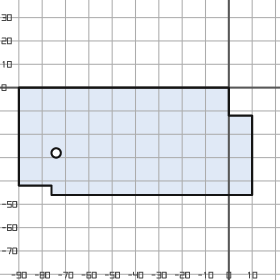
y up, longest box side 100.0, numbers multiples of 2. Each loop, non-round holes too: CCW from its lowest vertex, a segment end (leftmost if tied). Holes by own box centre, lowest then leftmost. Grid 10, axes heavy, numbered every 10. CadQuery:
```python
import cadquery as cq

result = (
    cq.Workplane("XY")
    .moveTo(-76.0, -46.0)
    .lineTo(10.0, -46.0)
    .lineTo(10.0, -12.0)
    .lineTo(0.0, -12.0)
    .lineTo(0.0, 0.0)
    .lineTo(-90.0, 0.0)
    .lineTo(-90.0, -42.0)
    .lineTo(-76.0, -42.0)
    .close()
    .moveTo(-74.0, -28.0)
    .circle(2.0)
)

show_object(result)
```